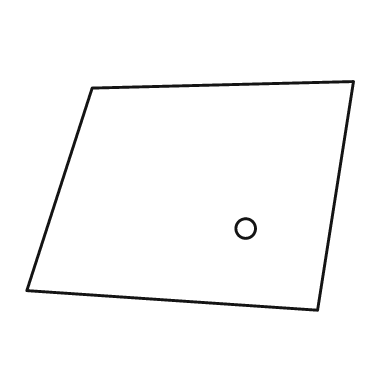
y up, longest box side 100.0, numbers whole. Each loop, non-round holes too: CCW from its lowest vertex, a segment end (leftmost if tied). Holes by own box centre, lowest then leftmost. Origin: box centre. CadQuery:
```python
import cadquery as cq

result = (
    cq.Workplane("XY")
    .moveTo(39.0, -35.0)
    .lineTo(50.0, 35.0)
    .lineTo(-30.0, 33.0)
    .lineTo(-50.0, -29.0)
    .close()
    .moveTo(17.0, -10.0)
    .circle(3.0)
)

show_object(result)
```